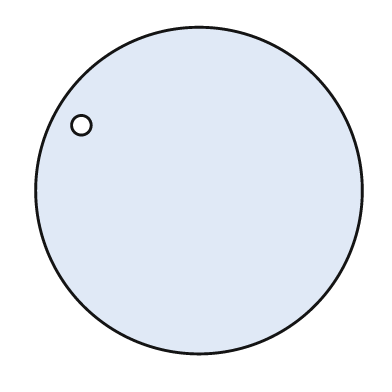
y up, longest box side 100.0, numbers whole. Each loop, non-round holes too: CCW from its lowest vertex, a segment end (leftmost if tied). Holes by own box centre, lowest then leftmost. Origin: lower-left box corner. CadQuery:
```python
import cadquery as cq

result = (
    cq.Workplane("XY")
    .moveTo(50.0, 50.0)
    .circle(50.0)
    .moveTo(14.0, 70.0)
    .circle(3.0)
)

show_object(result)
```